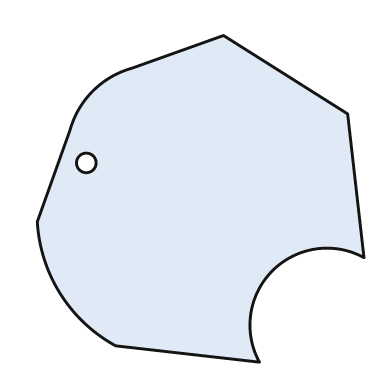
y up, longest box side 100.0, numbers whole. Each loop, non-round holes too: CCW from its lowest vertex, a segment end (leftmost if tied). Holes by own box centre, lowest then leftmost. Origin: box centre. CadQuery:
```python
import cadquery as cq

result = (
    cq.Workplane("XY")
    .moveTo(18.0, -50.0)
    .threePointArc((22.0, -22.0), (50.0, -18.0))
    .lineTo(45.0, 26.0)
    .lineTo(7.0, 50.0)
    .lineTo(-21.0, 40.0)
    .threePointArc((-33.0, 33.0), (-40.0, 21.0))
    .lineTo(-50.0, -7.0)
    .threePointArc((-43.0, -29.0), (-26.0, -45.0))
    .close()
    .moveTo(-35.0, 11.0)
    .circle(3.0)
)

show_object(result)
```